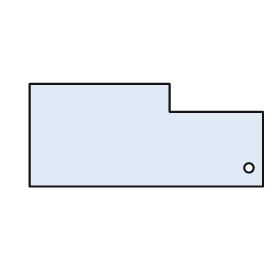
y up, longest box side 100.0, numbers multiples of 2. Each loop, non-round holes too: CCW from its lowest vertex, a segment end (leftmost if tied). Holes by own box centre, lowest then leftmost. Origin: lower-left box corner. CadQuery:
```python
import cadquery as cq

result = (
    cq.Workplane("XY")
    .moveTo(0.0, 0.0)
    .lineTo(100.0, 0.0)
    .lineTo(100.0, 32.0)
    .lineTo(60.0, 32.0)
    .lineTo(60.0, 44.0)
    .lineTo(0.0, 44.0)
    .close()
    .moveTo(94.0, 8.0)
    .circle(2.0)
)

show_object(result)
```